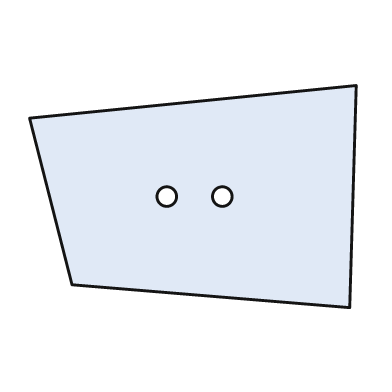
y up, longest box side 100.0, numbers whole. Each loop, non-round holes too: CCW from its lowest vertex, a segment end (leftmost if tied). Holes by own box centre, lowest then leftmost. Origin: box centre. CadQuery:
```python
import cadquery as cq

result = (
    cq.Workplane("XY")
    .moveTo(48.0, -34.0)
    .lineTo(50.0, 34.0)
    .lineTo(-50.0, 24.0)
    .lineTo(-37.0, -27.0)
    .close()
    .moveTo(-8.0, 0.0)
    .circle(3.0)
    .moveTo(9.0, 0.0)
    .circle(3.0)
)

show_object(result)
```